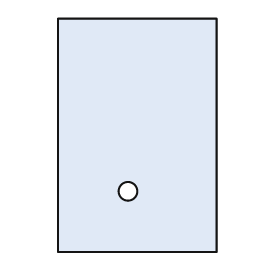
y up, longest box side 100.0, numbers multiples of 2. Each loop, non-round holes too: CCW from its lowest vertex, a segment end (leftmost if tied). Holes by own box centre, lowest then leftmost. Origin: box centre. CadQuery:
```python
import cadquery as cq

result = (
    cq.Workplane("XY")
    .moveTo(-34.0, -50.0)
    .lineTo(34.0, -50.0)
    .lineTo(34.0, 50.0)
    .lineTo(-34.0, 50.0)
    .close()
    .moveTo(-4.0, -24.0)
    .circle(4.0)
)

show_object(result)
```